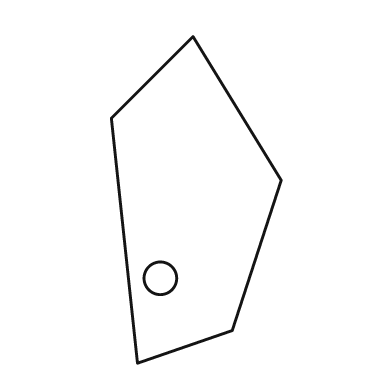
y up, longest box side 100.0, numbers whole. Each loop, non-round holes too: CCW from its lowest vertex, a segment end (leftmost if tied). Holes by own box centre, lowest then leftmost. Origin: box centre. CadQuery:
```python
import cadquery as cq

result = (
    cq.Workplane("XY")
    .moveTo(-18.0, -50.0)
    .lineTo(11.0, -40.0)
    .lineTo(26.0, 6.0)
    .lineTo(-1.0, 50.0)
    .lineTo(-26.0, 25.0)
    .close()
    .moveTo(-11.0, -24.0)
    .circle(5.0)
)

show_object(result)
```